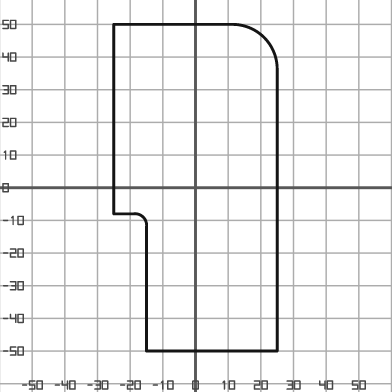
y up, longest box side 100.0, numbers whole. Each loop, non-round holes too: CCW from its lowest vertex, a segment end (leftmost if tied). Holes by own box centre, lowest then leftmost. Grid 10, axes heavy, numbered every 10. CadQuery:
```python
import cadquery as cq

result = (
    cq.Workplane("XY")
    .moveTo(-15.0, -50.0)
    .lineTo(25.0, -50.0)
    .lineTo(25.0, 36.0)
    .threePointArc((21.0, 46.0), (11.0, 50.0))
    .lineTo(-25.0, 50.0)
    .lineTo(-25.0, -8.0)
    .lineTo(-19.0, -8.0)
    .threePointArc((-16.0, -9.0), (-15.0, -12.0))
    .close()
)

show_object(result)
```